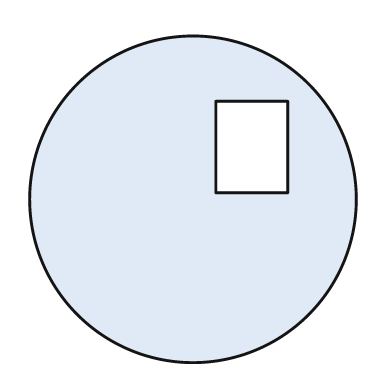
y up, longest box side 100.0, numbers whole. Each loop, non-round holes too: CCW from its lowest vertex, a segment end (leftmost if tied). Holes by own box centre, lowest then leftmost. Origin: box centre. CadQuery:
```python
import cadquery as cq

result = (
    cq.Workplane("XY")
    .moveTo(0.0, 0.0)
    .circle(50.0)
    .moveTo(7.0, 2.0)
    .lineTo(29.0, 2.0)
    .lineTo(29.0, 30.0)
    .lineTo(7.0, 30.0)
    .close()
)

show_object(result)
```